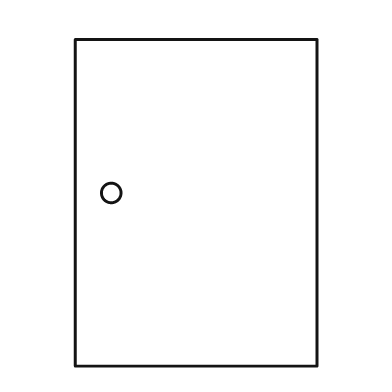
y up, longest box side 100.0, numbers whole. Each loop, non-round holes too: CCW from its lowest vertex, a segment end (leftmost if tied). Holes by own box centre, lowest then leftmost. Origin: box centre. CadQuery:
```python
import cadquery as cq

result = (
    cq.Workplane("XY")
    .moveTo(-37.0, -50.0)
    .lineTo(37.0, -50.0)
    .lineTo(37.0, 50.0)
    .lineTo(-37.0, 50.0)
    .close()
    .moveTo(-26.0, 3.0)
    .circle(3.0)
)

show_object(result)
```